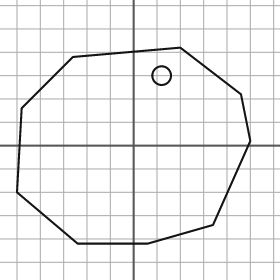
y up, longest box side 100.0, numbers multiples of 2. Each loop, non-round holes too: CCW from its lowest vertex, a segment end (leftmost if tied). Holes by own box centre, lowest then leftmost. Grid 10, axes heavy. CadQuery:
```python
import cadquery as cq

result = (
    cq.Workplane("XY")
    .moveTo(-24.0, -42.0)
    .lineTo(6.0, -42.0)
    .lineTo(34.0, -34.0)
    .lineTo(50.0, 2.0)
    .lineTo(46.0, 22.0)
    .lineTo(20.0, 42.0)
    .lineTo(-26.0, 38.0)
    .lineTo(-48.0, 16.0)
    .lineTo(-50.0, -20.0)
    .close()
    .moveTo(12.0, 30.0)
    .circle(4.0)
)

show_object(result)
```